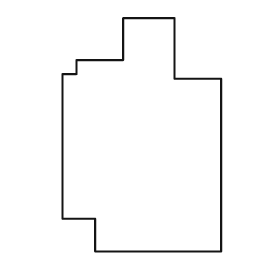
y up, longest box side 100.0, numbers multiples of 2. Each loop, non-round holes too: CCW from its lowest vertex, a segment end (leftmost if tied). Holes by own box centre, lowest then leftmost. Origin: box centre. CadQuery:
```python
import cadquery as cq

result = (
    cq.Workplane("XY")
    .moveTo(-20.0, -50.0)
    .lineTo(34.0, -50.0)
    .lineTo(34.0, 24.0)
    .lineTo(14.0, 24.0)
    .lineTo(14.0, 50.0)
    .lineTo(-8.0, 50.0)
    .lineTo(-8.0, 32.0)
    .lineTo(-28.0, 32.0)
    .lineTo(-28.0, 26.0)
    .lineTo(-34.0, 26.0)
    .lineTo(-34.0, -36.0)
    .lineTo(-20.0, -36.0)
    .close()
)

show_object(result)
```